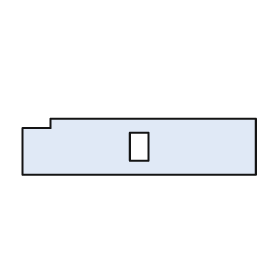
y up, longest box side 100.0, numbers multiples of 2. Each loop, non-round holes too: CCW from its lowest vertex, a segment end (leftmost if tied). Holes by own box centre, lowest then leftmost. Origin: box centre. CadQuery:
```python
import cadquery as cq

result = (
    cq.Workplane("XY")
    .moveTo(-50.0, -12.0)
    .lineTo(50.0, -12.0)
    .lineTo(50.0, 12.0)
    .lineTo(-38.0, 12.0)
    .lineTo(-38.0, 8.0)
    .lineTo(-50.0, 8.0)
    .close()
    .moveTo(-4.0, -6.0)
    .lineTo(4.0, -6.0)
    .lineTo(4.0, 6.0)
    .lineTo(-4.0, 6.0)
    .close()
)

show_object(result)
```